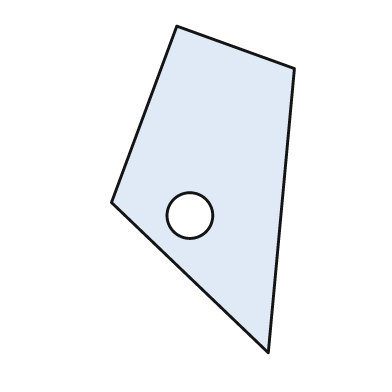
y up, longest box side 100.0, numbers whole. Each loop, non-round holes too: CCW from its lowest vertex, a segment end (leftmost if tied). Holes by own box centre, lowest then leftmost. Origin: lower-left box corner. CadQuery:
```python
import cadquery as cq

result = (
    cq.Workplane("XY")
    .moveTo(48.0, 0.0)
    .lineTo(56.0, 87.0)
    .lineTo(20.0, 100.0)
    .lineTo(0.0, 46.0)
    .close()
    .moveTo(24.0, 42.0)
    .circle(7.0)
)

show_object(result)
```